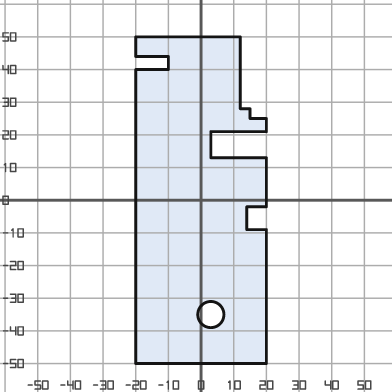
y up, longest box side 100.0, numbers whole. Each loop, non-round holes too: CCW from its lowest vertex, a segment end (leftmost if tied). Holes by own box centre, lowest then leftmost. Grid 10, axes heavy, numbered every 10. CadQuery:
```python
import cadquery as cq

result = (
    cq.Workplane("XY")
    .moveTo(-20.0, -50.0)
    .lineTo(20.0, -50.0)
    .lineTo(20.0, -9.0)
    .lineTo(14.0, -9.0)
    .lineTo(14.0, -2.0)
    .lineTo(20.0, -2.0)
    .lineTo(20.0, 13.0)
    .lineTo(3.0, 13.0)
    .lineTo(3.0, 21.0)
    .lineTo(20.0, 21.0)
    .lineTo(20.0, 25.0)
    .lineTo(15.0, 25.0)
    .lineTo(15.0, 28.0)
    .lineTo(12.0, 28.0)
    .lineTo(12.0, 50.0)
    .lineTo(-20.0, 50.0)
    .lineTo(-20.0, 44.0)
    .lineTo(-10.0, 44.0)
    .lineTo(-10.0, 40.0)
    .lineTo(-20.0, 40.0)
    .close()
    .moveTo(3.0, -35.0)
    .circle(4.0)
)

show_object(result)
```